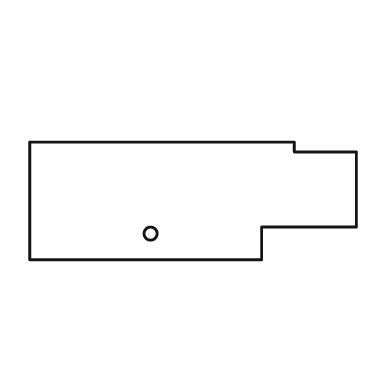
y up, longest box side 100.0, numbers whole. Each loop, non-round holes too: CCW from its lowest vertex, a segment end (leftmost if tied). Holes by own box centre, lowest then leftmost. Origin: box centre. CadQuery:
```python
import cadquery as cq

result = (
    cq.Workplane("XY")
    .moveTo(-50.0, -18.0)
    .lineTo(21.0, -18.0)
    .lineTo(21.0, -8.0)
    .lineTo(50.0, -8.0)
    .lineTo(50.0, 15.0)
    .lineTo(31.0, 15.0)
    .lineTo(31.0, 18.0)
    .lineTo(-50.0, 18.0)
    .close()
    .moveTo(-13.0, -10.0)
    .circle(2.0)
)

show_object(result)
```